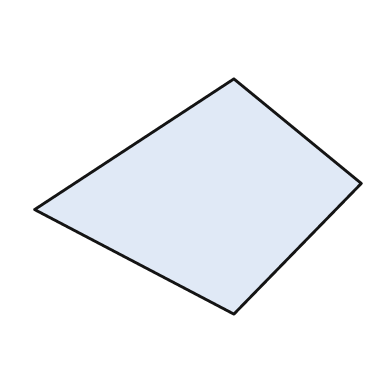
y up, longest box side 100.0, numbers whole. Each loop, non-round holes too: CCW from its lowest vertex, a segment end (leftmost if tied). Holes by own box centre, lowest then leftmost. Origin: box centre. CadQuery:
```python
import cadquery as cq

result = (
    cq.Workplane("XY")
    .moveTo(11.0, -36.0)
    .lineTo(50.0, 4.0)
    .lineTo(11.0, 36.0)
    .lineTo(-50.0, -4.0)
    .close()
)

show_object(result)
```